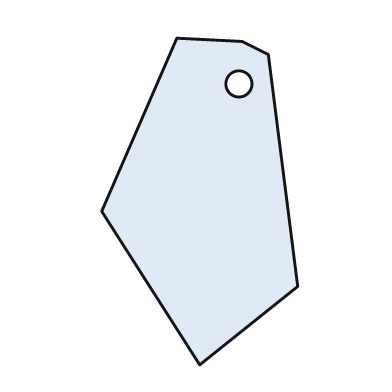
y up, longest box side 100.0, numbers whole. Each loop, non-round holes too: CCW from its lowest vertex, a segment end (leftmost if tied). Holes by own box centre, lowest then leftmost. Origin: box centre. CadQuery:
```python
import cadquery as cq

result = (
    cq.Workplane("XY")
    .moveTo(0.0, -50.0)
    .lineTo(30.0, -26.0)
    .lineTo(21.0, 45.0)
    .lineTo(13.0, 49.0)
    .lineTo(-7.0, 50.0)
    .lineTo(-30.0, -3.0)
    .close()
    .moveTo(12.0, 36.0)
    .circle(4.0)
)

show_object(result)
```